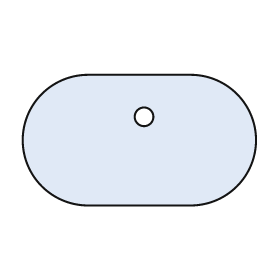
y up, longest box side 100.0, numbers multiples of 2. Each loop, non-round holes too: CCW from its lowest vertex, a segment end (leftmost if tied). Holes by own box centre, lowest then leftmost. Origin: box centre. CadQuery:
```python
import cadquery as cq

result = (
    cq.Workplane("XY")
    .moveTo(-22.0, -28.0)
    .lineTo(22.0, -28.0)
    .threePointArc((50.0, 0.0), (22.0, 28.0))
    .lineTo(-22.0, 28.0)
    .threePointArc((-50.0, 0.0), (-22.0, -28.0))
    .close()
    .moveTo(2.0, 10.0)
    .circle(4.0)
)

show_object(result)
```